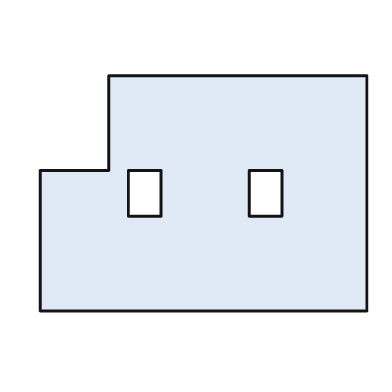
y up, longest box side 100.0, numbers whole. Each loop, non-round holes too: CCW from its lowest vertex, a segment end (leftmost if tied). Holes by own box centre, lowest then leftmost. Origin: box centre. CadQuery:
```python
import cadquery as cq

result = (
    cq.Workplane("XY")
    .moveTo(-50.0, -36.0)
    .lineTo(50.0, -36.0)
    .lineTo(50.0, 36.0)
    .lineTo(-29.0, 36.0)
    .lineTo(-29.0, 7.0)
    .lineTo(-50.0, 7.0)
    .close()
    .moveTo(-23.0, -7.0)
    .lineTo(-13.0, -7.0)
    .lineTo(-13.0, 7.0)
    .lineTo(-23.0, 7.0)
    .close()
    .moveTo(14.0, -7.0)
    .lineTo(24.0, -7.0)
    .lineTo(24.0, 7.0)
    .lineTo(14.0, 7.0)
    .close()
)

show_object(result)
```